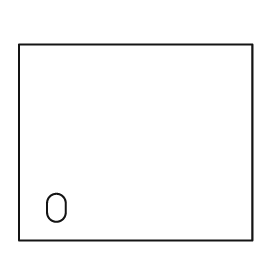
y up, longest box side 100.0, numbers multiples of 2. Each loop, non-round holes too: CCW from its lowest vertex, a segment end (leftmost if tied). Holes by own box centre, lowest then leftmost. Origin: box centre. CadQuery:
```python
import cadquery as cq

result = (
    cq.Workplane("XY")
    .moveTo(-50.0, -42.0)
    .lineTo(50.0, -42.0)
    .lineTo(50.0, 42.0)
    .lineTo(-50.0, 42.0)
    .close()
    .moveTo(-38.0, -30.0)
    .threePointArc((-34.0, -34.0), (-30.0, -30.0))
    .lineTo(-30.0, -26.0)
    .threePointArc((-34.0, -22.0), (-38.0, -26.0))
    .close()
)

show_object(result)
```